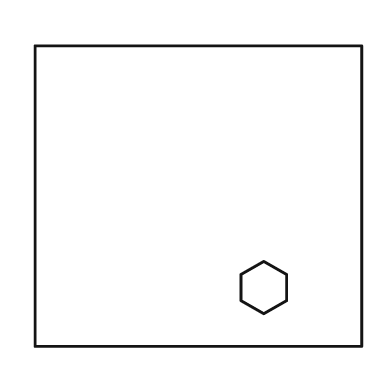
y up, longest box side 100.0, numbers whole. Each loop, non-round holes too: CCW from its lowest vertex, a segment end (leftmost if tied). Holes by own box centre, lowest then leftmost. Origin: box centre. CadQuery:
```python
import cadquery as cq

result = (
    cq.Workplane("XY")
    .moveTo(-50.0, -46.0)
    .lineTo(50.0, -46.0)
    .lineTo(50.0, 46.0)
    .lineTo(-50.0, 46.0)
    .close()
    .moveTo(20.0, -36.0)
    .lineTo(27.0, -32.0)
    .lineTo(27.0, -24.0)
    .lineTo(20.0, -20.0)
    .lineTo(13.0, -24.0)
    .lineTo(13.0, -32.0)
    .close()
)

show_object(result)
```